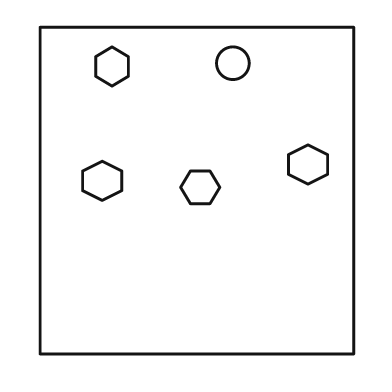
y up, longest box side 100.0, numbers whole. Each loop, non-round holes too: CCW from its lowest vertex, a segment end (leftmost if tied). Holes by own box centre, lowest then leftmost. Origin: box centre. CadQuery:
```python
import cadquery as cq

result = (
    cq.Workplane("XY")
    .moveTo(-48.0, -50.0)
    .lineTo(48.0, -50.0)
    .lineTo(48.0, 50.0)
    .lineTo(-48.0, 50.0)
    .close()
    .moveTo(-2.0, -4.0)
    .lineTo(4.0, -4.0)
    .lineTo(7.0, 1.0)
    .lineTo(4.0, 6.0)
    .lineTo(-2.0, 6.0)
    .lineTo(-5.0, 1.0)
    .close()
    .moveTo(-29.0, -3.0)
    .lineTo(-23.0, 0.0)
    .lineTo(-23.0, 6.0)
    .lineTo(-29.0, 9.0)
    .lineTo(-35.0, 6.0)
    .lineTo(-35.0, 0.0)
    .close()
    .moveTo(34.0, 2.0)
    .lineTo(40.0, 5.0)
    .lineTo(40.0, 11.0)
    .lineTo(34.0, 14.0)
    .lineTo(28.0, 11.0)
    .lineTo(28.0, 5.0)
    .close()
    .moveTo(-26.0, 32.0)
    .lineTo(-21.0, 35.0)
    .lineTo(-21.0, 41.0)
    .lineTo(-26.0, 44.0)
    .lineTo(-31.0, 41.0)
    .lineTo(-31.0, 35.0)
    .close()
    .moveTo(11.0, 39.0)
    .circle(5.0)
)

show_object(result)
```